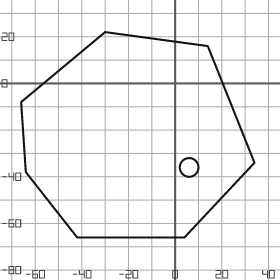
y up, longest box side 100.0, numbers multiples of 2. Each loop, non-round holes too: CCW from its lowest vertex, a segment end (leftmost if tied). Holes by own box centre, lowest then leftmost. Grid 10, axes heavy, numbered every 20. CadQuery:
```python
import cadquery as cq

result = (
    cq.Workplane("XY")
    .moveTo(-42.0, -66.0)
    .lineTo(4.0, -66.0)
    .lineTo(34.0, -34.0)
    .lineTo(14.0, 16.0)
    .lineTo(-30.0, 22.0)
    .lineTo(-66.0, -8.0)
    .lineTo(-64.0, -38.0)
    .close()
    .moveTo(6.0, -36.0)
    .circle(4.0)
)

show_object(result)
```